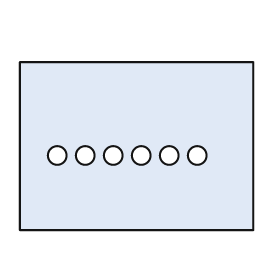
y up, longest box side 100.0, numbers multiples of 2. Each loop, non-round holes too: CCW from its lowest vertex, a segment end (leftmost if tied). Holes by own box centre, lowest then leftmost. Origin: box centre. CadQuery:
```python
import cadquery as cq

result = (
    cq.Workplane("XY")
    .moveTo(-50.0, -36.0)
    .lineTo(50.0, -36.0)
    .lineTo(50.0, 36.0)
    .lineTo(-50.0, 36.0)
    .close()
    .moveTo(-34.0, -4.0)
    .circle(4.0)
    .moveTo(-22.0, -4.0)
    .circle(4.0)
    .moveTo(-10.0, -4.0)
    .circle(4.0)
    .moveTo(2.0, -4.0)
    .circle(4.0)
    .moveTo(14.0, -4.0)
    .circle(4.0)
    .moveTo(26.0, -4.0)
    .circle(4.0)
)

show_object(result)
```